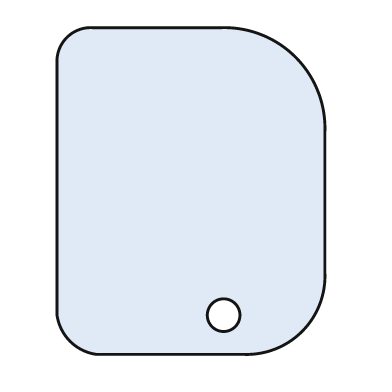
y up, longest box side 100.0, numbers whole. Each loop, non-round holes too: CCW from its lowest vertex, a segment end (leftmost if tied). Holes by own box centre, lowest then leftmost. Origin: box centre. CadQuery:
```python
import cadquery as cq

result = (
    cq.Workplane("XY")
    .moveTo(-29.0, -50.0)
    .lineTo(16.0, -50.0)
    .threePointArc((34.0, -43.0), (41.0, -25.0))
    .lineTo(41.0, 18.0)
    .threePointArc((32.0, 41.0), (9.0, 50.0))
    .lineTo(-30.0, 50.0)
    .threePointArc((-38.0, 47.0), (-41.0, 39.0))
    .lineTo(-41.0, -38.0)
    .threePointArc((-37.0, -46.0), (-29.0, -50.0))
    .close()
    .moveTo(10.0, -38.0)
    .circle(5.0)
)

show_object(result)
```